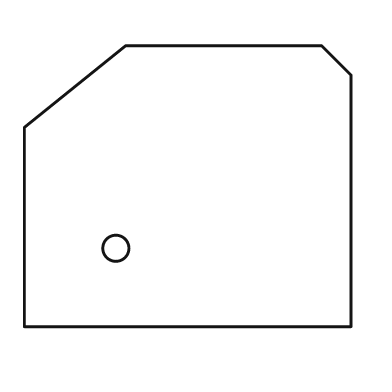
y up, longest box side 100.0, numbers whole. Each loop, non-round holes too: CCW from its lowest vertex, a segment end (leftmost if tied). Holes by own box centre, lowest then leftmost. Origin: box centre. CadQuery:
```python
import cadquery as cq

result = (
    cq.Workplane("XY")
    .moveTo(-50.0, -43.0)
    .lineTo(50.0, -43.0)
    .lineTo(50.0, 34.0)
    .lineTo(41.0, 43.0)
    .lineTo(-19.0, 43.0)
    .lineTo(-50.0, 18.0)
    .close()
    .moveTo(-22.0, -19.0)
    .circle(4.0)
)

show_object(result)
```